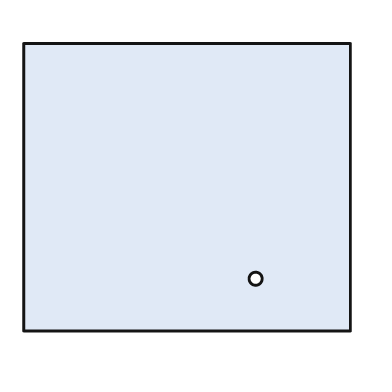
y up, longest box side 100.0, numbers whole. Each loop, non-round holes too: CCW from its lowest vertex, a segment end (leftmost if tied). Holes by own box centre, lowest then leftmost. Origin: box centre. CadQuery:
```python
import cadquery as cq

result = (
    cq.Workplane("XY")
    .moveTo(-50.0, -44.0)
    .lineTo(50.0, -44.0)
    .lineTo(50.0, 44.0)
    .lineTo(-50.0, 44.0)
    .close()
    .moveTo(21.0, -28.0)
    .circle(2.0)
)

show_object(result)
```